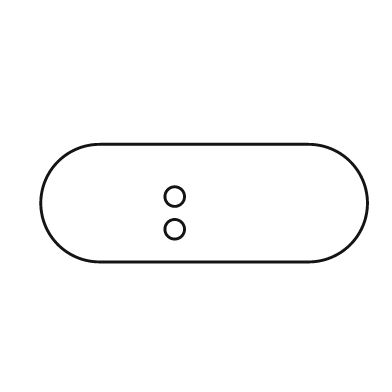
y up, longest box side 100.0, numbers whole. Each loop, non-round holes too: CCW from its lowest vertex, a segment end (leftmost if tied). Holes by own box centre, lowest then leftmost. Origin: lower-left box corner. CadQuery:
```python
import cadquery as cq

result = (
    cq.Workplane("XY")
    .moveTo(18.0, 0.0)
    .lineTo(82.0, 0.0)
    .threePointArc((100.0, 18.0), (82.0, 36.0))
    .lineTo(18.0, 36.0)
    .threePointArc((0.0, 18.0), (18.0, 0.0))
    .close()
    .moveTo(41.0, 10.0)
    .circle(3.0)
    .moveTo(41.0, 20.0)
    .circle(3.0)
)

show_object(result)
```